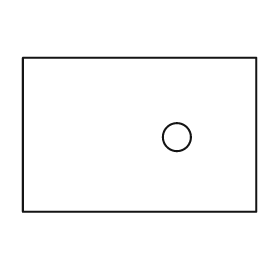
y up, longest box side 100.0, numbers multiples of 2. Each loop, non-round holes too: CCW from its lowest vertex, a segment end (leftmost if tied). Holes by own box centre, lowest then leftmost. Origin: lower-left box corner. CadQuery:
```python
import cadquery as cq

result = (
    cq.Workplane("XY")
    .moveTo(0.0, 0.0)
    .lineTo(100.0, 0.0)
    .lineTo(100.0, 66.0)
    .lineTo(0.0, 66.0)
    .close()
    .moveTo(66.0, 32.0)
    .circle(6.0)
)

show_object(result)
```